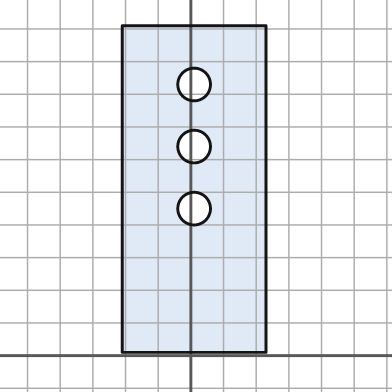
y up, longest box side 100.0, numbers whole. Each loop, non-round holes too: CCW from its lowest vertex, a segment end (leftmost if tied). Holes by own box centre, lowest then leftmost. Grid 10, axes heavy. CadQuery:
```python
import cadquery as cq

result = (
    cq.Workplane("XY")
    .moveTo(-21.0, 1.0)
    .lineTo(23.0, 1.0)
    .lineTo(23.0, 101.0)
    .lineTo(-21.0, 101.0)
    .close()
    .moveTo(1.0, 45.0)
    .circle(5.0)
    .moveTo(1.0, 64.0)
    .circle(5.0)
    .moveTo(1.0, 83.0)
    .circle(5.0)
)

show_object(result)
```